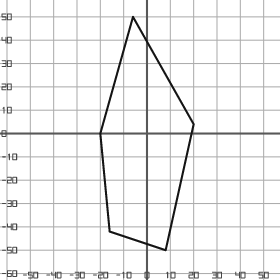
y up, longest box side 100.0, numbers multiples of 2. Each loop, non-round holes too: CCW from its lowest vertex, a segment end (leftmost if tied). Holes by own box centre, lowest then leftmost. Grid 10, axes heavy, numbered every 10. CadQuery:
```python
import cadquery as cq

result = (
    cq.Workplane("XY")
    .moveTo(8.0, -50.0)
    .lineTo(20.0, 4.0)
    .lineTo(-6.0, 50.0)
    .lineTo(-20.0, 0.0)
    .lineTo(-16.0, -42.0)
    .close()
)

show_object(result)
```